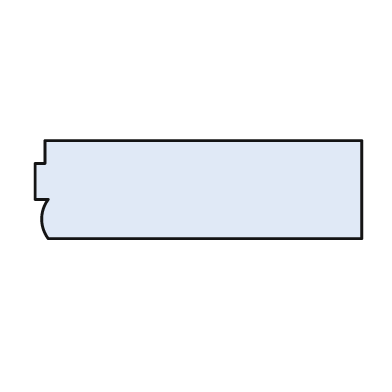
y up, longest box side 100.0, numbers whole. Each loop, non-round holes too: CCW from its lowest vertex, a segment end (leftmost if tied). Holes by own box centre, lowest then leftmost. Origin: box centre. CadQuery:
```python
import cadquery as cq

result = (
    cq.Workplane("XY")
    .moveTo(-46.0, -15.0)
    .lineTo(50.0, -15.0)
    .lineTo(50.0, 15.0)
    .lineTo(-47.0, 15.0)
    .lineTo(-47.0, 8.0)
    .lineTo(-50.0, 8.0)
    .lineTo(-50.0, -3.0)
    .lineTo(-46.0, -3.0)
    .threePointArc((-48.0, -9.0), (-46.0, -15.0))
    .close()
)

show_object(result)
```